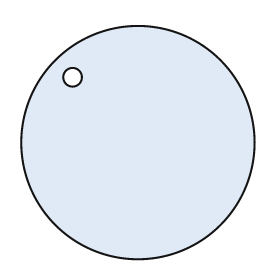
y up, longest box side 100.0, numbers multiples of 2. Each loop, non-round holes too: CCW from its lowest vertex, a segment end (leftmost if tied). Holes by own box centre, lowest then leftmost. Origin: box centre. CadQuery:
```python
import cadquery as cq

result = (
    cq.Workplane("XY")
    .moveTo(0.0, 0.0)
    .circle(50.0)
    .moveTo(-28.0, 28.0)
    .circle(4.0)
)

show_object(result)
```